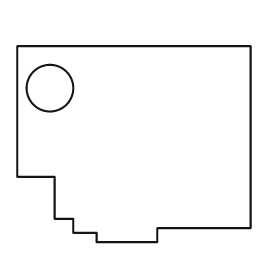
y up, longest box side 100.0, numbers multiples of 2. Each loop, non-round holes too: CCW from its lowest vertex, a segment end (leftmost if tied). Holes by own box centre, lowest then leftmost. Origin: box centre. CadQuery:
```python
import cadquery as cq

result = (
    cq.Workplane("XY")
    .moveTo(-16.0, -42.0)
    .lineTo(10.0, -42.0)
    .lineTo(10.0, -36.0)
    .lineTo(50.0, -36.0)
    .lineTo(50.0, 42.0)
    .lineTo(-50.0, 42.0)
    .lineTo(-50.0, -14.0)
    .lineTo(-34.0, -14.0)
    .lineTo(-34.0, -32.0)
    .lineTo(-26.0, -32.0)
    .lineTo(-26.0, -38.0)
    .lineTo(-16.0, -38.0)
    .close()
    .moveTo(-36.0, 24.0)
    .circle(10.0)
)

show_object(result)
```